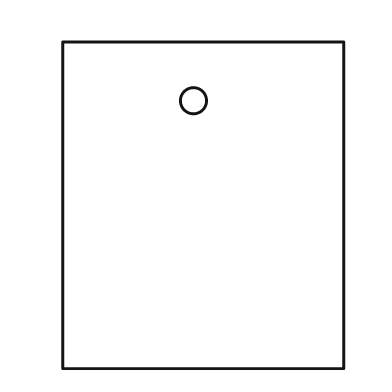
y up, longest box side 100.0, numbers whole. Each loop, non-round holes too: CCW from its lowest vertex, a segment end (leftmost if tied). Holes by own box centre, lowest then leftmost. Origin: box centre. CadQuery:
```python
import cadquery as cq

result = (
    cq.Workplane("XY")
    .moveTo(-43.0, -50.0)
    .lineTo(43.0, -50.0)
    .lineTo(43.0, 50.0)
    .lineTo(-43.0, 50.0)
    .close()
    .moveTo(-3.0, 32.0)
    .circle(4.0)
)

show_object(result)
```